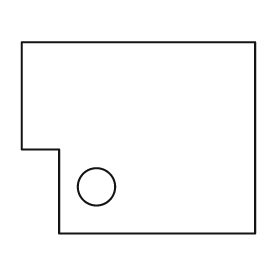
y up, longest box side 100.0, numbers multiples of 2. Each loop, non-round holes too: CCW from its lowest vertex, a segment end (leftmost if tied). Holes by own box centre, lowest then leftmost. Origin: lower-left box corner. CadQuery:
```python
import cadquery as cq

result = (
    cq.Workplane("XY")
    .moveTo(16.0, 0.0)
    .lineTo(100.0, 0.0)
    .lineTo(100.0, 82.0)
    .lineTo(0.0, 82.0)
    .lineTo(0.0, 36.0)
    .lineTo(16.0, 36.0)
    .close()
    .moveTo(32.0, 20.0)
    .circle(8.0)
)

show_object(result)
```